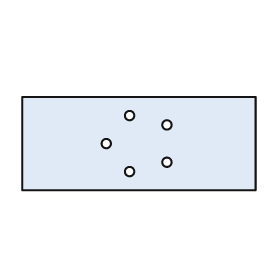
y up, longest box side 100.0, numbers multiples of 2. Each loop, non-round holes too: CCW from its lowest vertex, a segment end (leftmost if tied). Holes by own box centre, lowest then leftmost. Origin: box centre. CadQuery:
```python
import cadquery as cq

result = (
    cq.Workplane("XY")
    .moveTo(-50.0, -20.0)
    .lineTo(50.0, -20.0)
    .lineTo(50.0, 20.0)
    .lineTo(-50.0, 20.0)
    .close()
    .moveTo(-4.0, -12.0)
    .circle(2.0)
    .moveTo(12.0, -8.0)
    .circle(2.0)
    .moveTo(-14.0, 0.0)
    .circle(2.0)
    .moveTo(12.0, 8.0)
    .circle(2.0)
    .moveTo(-4.0, 12.0)
    .circle(2.0)
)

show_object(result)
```